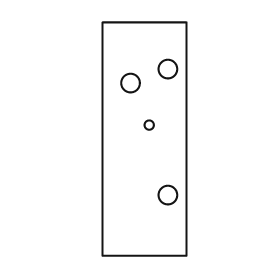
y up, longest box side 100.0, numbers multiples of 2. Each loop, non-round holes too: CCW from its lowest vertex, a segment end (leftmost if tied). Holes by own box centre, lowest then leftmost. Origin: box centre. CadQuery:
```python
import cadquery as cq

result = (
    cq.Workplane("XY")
    .moveTo(-18.0, -50.0)
    .lineTo(18.0, -50.0)
    .lineTo(18.0, 50.0)
    .lineTo(-18.0, 50.0)
    .close()
    .moveTo(10.0, -24.0)
    .circle(4.0)
    .moveTo(2.0, 6.0)
    .circle(2.0)
    .moveTo(-6.0, 24.0)
    .circle(4.0)
    .moveTo(10.0, 30.0)
    .circle(4.0)
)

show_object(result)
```